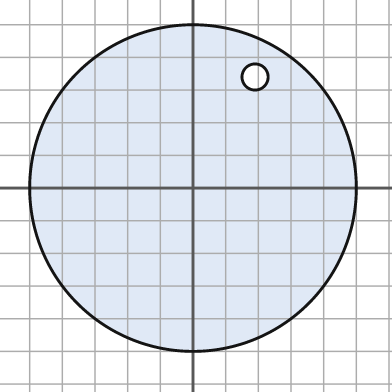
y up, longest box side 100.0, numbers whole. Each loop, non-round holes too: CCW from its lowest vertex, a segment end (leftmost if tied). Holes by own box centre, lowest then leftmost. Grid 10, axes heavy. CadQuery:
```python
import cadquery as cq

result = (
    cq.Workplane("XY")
    .moveTo(0.0, 0.0)
    .circle(50.0)
    .moveTo(19.0, 34.0)
    .circle(4.0)
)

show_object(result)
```